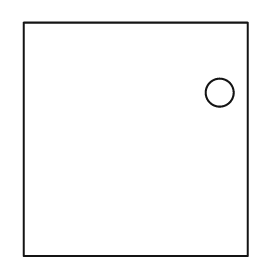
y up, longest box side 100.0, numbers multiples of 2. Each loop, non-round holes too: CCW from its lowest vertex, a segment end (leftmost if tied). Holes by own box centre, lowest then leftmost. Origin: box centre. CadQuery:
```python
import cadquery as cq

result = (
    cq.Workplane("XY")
    .moveTo(-48.0, -50.0)
    .lineTo(48.0, -50.0)
    .lineTo(48.0, 50.0)
    .lineTo(-48.0, 50.0)
    .close()
    .moveTo(36.0, 20.0)
    .circle(6.0)
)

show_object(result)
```